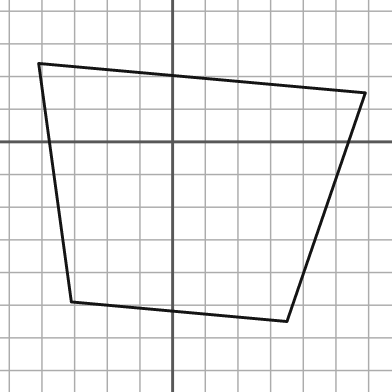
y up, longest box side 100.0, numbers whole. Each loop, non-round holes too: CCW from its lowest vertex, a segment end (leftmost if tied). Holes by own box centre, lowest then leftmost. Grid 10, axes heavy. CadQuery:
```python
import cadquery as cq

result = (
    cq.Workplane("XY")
    .moveTo(35.0, -55.0)
    .lineTo(59.0, 15.0)
    .lineTo(-41.0, 24.0)
    .lineTo(-31.0, -49.0)
    .close()
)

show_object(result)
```